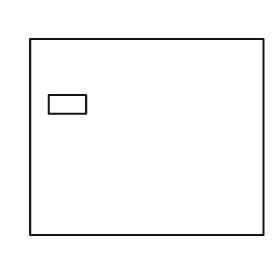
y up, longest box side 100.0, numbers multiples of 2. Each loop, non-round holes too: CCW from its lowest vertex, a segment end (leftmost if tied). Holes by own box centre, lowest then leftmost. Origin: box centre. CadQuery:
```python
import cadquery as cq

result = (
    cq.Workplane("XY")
    .moveTo(-50.0, -42.0)
    .lineTo(50.0, -42.0)
    .lineTo(50.0, 42.0)
    .lineTo(-50.0, 42.0)
    .close()
    .moveTo(-42.0, 10.0)
    .lineTo(-26.0, 10.0)
    .lineTo(-26.0, 18.0)
    .lineTo(-42.0, 18.0)
    .close()
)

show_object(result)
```